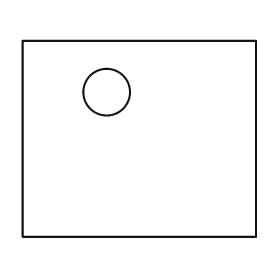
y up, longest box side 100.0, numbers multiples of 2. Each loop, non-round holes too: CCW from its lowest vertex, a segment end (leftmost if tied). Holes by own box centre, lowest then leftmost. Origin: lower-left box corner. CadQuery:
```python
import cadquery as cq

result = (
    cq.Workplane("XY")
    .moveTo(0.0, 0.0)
    .lineTo(100.0, 0.0)
    .lineTo(100.0, 84.0)
    .lineTo(0.0, 84.0)
    .close()
    .moveTo(36.0, 62.0)
    .circle(10.0)
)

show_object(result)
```